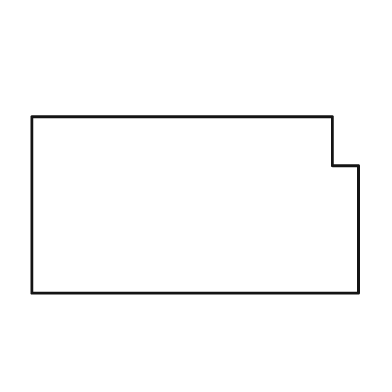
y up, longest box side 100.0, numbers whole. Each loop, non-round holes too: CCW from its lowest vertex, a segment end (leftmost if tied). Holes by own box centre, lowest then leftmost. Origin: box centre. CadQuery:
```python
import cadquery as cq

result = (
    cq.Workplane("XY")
    .moveTo(-50.0, -27.0)
    .lineTo(50.0, -27.0)
    .lineTo(50.0, 12.0)
    .lineTo(42.0, 12.0)
    .lineTo(42.0, 27.0)
    .lineTo(-50.0, 27.0)
    .close()
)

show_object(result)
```